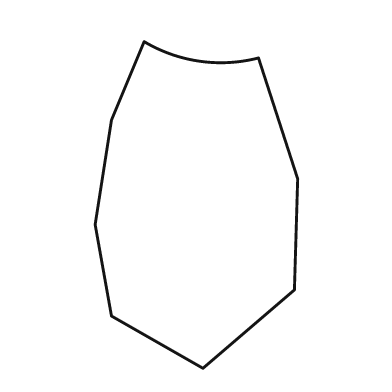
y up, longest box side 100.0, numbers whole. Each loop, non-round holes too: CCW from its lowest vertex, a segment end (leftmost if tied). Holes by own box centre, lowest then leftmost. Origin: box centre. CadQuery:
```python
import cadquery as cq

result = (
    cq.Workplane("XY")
    .moveTo(2.0, -50.0)
    .lineTo(30.0, -26.0)
    .lineTo(31.0, 8.0)
    .lineTo(19.0, 45.0)
    .threePointArc((1.0, 44.0), (-16.0, 50.0))
    .lineTo(-26.0, 26.0)
    .lineTo(-31.0, -6.0)
    .lineTo(-26.0, -34.0)
    .close()
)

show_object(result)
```